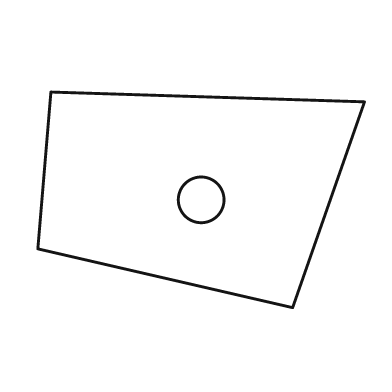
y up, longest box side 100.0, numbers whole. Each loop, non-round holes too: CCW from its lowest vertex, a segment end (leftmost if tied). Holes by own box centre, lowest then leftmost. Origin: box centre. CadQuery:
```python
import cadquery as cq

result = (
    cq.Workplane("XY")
    .moveTo(28.0, -33.0)
    .lineTo(50.0, 30.0)
    .lineTo(-46.0, 33.0)
    .lineTo(-50.0, -15.0)
    .close()
    .moveTo(0.0, 0.0)
    .circle(7.0)
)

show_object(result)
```